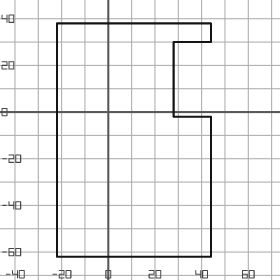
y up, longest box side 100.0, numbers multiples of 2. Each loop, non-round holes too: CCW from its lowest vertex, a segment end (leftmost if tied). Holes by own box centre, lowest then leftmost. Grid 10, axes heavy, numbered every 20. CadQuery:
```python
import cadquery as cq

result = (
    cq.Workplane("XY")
    .moveTo(-22.0, -62.0)
    .lineTo(44.0, -62.0)
    .lineTo(44.0, -2.0)
    .lineTo(28.0, -2.0)
    .lineTo(28.0, 30.0)
    .lineTo(44.0, 30.0)
    .lineTo(44.0, 38.0)
    .lineTo(-22.0, 38.0)
    .close()
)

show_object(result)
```